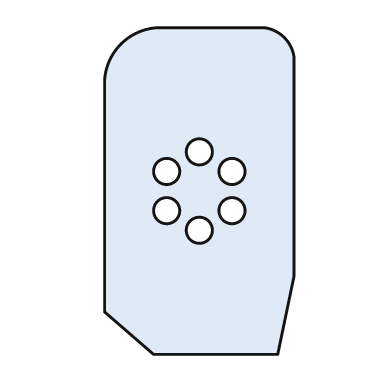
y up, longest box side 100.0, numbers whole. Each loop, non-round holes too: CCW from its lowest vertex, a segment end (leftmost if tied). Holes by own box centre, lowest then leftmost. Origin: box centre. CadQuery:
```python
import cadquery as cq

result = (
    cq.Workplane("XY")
    .moveTo(-14.0, -50.0)
    .lineTo(24.0, -50.0)
    .lineTo(29.0, -26.0)
    .lineTo(29.0, 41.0)
    .threePointArc((26.0, 47.0), (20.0, 50.0))
    .lineTo(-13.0, 50.0)
    .threePointArc((-24.0, 45.0), (-29.0, 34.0))
    .lineTo(-29.0, -37.0)
    .close()
    .moveTo(0.0, -12.0)
    .circle(4.0)
    .moveTo(-10.0, -6.0)
    .circle(4.0)
    .moveTo(10.0, -6.0)
    .circle(4.0)
    .moveTo(-10.0, 6.0)
    .circle(4.0)
    .moveTo(10.0, 6.0)
    .circle(4.0)
    .moveTo(0.0, 12.0)
    .circle(4.0)
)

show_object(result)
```